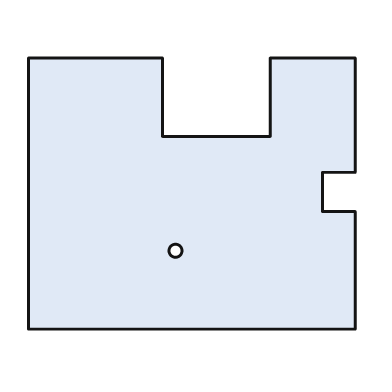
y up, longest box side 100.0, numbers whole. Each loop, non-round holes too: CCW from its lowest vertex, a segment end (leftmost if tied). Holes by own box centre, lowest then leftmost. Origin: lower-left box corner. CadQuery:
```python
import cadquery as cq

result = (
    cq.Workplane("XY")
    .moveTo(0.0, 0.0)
    .lineTo(100.0, 0.0)
    .lineTo(100.0, 36.0)
    .lineTo(90.0, 36.0)
    .lineTo(90.0, 48.0)
    .lineTo(100.0, 48.0)
    .lineTo(100.0, 83.0)
    .lineTo(74.0, 83.0)
    .lineTo(74.0, 59.0)
    .lineTo(41.0, 59.0)
    .lineTo(41.0, 83.0)
    .lineTo(0.0, 83.0)
    .close()
    .moveTo(45.0, 24.0)
    .circle(2.0)
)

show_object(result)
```